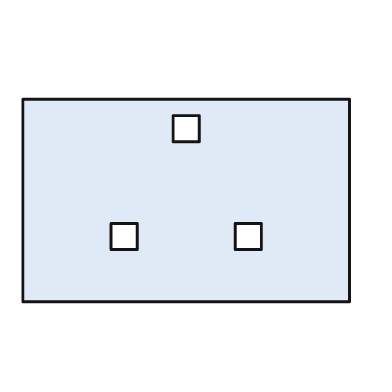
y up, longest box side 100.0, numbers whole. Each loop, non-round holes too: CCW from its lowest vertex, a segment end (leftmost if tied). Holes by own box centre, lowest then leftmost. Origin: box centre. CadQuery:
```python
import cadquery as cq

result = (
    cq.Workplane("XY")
    .moveTo(-50.0, -31.0)
    .lineTo(50.0, -31.0)
    .lineTo(50.0, 31.0)
    .lineTo(-50.0, 31.0)
    .close()
    .moveTo(-23.0, -15.0)
    .lineTo(-15.0, -15.0)
    .lineTo(-15.0, -7.0)
    .lineTo(-23.0, -7.0)
    .close()
    .moveTo(15.0, -15.0)
    .lineTo(23.0, -15.0)
    .lineTo(23.0, -7.0)
    .lineTo(15.0, -7.0)
    .close()
    .moveTo(-4.0, 18.0)
    .lineTo(4.0, 18.0)
    .lineTo(4.0, 26.0)
    .lineTo(-4.0, 26.0)
    .close()
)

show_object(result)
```